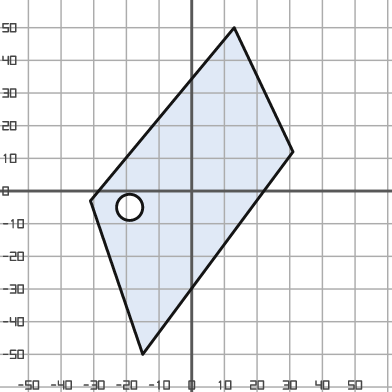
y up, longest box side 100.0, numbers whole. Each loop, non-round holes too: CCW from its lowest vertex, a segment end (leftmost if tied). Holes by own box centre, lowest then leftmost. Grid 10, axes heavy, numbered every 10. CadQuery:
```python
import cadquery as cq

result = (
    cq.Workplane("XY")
    .moveTo(-15.0, -50.0)
    .lineTo(31.0, 12.0)
    .lineTo(13.0, 50.0)
    .lineTo(-31.0, -3.0)
    .close()
    .moveTo(-19.0, -5.0)
    .circle(4.0)
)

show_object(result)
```